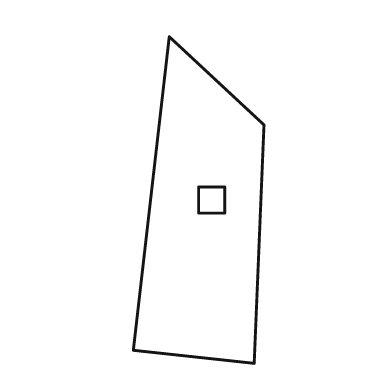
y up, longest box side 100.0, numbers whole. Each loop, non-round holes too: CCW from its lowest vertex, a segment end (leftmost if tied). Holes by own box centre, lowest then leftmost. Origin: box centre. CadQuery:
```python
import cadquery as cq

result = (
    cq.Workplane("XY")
    .moveTo(17.0, -50.0)
    .lineTo(20.0, 23.0)
    .lineTo(-9.0, 50.0)
    .lineTo(-20.0, -46.0)
    .close()
    .moveTo(0.0, -4.0)
    .lineTo(8.0, -4.0)
    .lineTo(8.0, 4.0)
    .lineTo(0.0, 4.0)
    .close()
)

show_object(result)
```